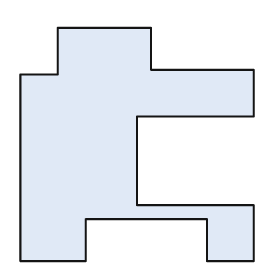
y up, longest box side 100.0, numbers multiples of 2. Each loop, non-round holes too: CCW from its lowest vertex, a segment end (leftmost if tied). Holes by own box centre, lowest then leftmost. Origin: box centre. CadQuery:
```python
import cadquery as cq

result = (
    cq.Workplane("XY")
    .moveTo(-50.0, -50.0)
    .lineTo(-22.0, -50.0)
    .lineTo(-22.0, -32.0)
    .lineTo(30.0, -32.0)
    .lineTo(30.0, -50.0)
    .lineTo(50.0, -50.0)
    .lineTo(50.0, -26.0)
    .lineTo(0.0, -26.0)
    .lineTo(0.0, 12.0)
    .lineTo(50.0, 12.0)
    .lineTo(50.0, 32.0)
    .lineTo(6.0, 32.0)
    .lineTo(6.0, 50.0)
    .lineTo(-34.0, 50.0)
    .lineTo(-34.0, 30.0)
    .lineTo(-50.0, 30.0)
    .close()
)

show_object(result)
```